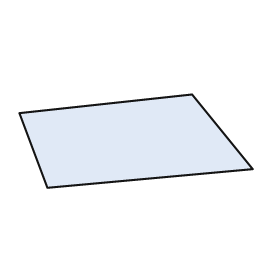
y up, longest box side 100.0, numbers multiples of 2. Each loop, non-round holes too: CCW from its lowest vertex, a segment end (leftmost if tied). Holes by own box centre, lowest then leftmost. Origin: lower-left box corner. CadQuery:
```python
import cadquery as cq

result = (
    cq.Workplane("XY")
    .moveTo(12.0, 0.0)
    .lineTo(100.0, 8.0)
    .lineTo(74.0, 40.0)
    .lineTo(0.0, 32.0)
    .close()
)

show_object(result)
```